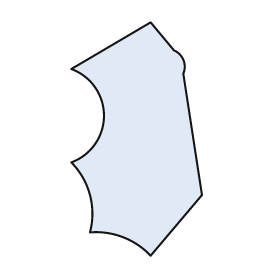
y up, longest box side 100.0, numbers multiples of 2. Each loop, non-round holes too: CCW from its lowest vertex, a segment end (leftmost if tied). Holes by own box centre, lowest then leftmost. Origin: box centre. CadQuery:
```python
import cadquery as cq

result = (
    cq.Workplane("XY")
    .moveTo(6.0, -50.0)
    .lineTo(28.0, -24.0)
    .lineTo(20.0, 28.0)
    .threePointArc((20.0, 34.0), (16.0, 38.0))
    .lineTo(6.0, 50.0)
    .lineTo(-28.0, 30.0)
    .threePointArc((-14.0, 10.0), (-28.0, -10.0))
    .threePointArc((-20.0, -24.0), (-20.0, -40.0))
    .threePointArc((-6.0, -42.0), (6.0, -50.0))
    .close()
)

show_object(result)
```